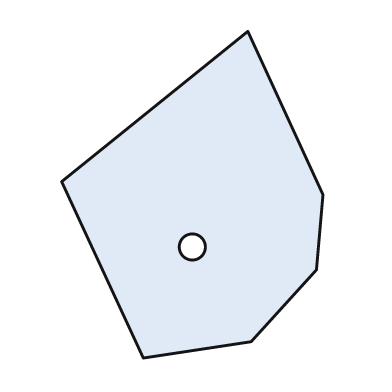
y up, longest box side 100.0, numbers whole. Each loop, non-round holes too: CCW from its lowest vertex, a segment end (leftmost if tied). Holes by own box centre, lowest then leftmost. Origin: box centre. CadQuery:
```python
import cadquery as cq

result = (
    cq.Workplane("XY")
    .moveTo(-15.0, -50.0)
    .lineTo(18.0, -45.0)
    .lineTo(38.0, -23.0)
    .lineTo(40.0, 0.0)
    .lineTo(17.0, 50.0)
    .lineTo(-40.0, 4.0)
    .close()
    .moveTo(0.0, -16.0)
    .circle(4.0)
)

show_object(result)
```